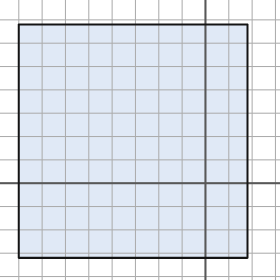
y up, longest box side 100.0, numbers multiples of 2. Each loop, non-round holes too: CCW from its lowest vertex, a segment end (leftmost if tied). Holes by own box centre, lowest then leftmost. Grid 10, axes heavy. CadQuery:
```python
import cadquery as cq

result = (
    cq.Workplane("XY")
    .moveTo(-80.0, -32.0)
    .lineTo(18.0, -32.0)
    .lineTo(18.0, 68.0)
    .lineTo(-80.0, 68.0)
    .close()
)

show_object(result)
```